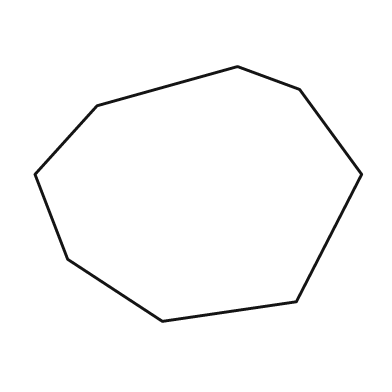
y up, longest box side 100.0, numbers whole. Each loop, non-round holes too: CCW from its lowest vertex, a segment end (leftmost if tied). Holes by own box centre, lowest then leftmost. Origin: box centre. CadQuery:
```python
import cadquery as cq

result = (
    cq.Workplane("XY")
    .moveTo(-11.0, -39.0)
    .lineTo(30.0, -33.0)
    .lineTo(50.0, 6.0)
    .lineTo(31.0, 32.0)
    .lineTo(12.0, 39.0)
    .lineTo(-31.0, 27.0)
    .lineTo(-50.0, 6.0)
    .lineTo(-40.0, -20.0)
    .close()
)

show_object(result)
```